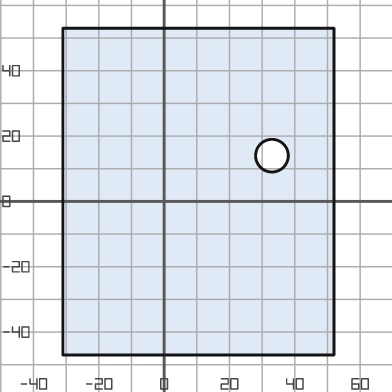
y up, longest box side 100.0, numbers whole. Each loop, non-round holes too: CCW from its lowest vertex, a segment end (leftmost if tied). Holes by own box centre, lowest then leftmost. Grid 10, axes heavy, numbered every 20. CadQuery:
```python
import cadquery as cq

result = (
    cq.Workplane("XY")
    .moveTo(-31.0, -47.0)
    .lineTo(52.0, -47.0)
    .lineTo(52.0, 53.0)
    .lineTo(-31.0, 53.0)
    .close()
    .moveTo(33.0, 14.0)
    .circle(5.0)
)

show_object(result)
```